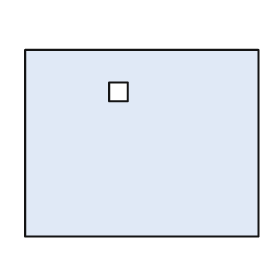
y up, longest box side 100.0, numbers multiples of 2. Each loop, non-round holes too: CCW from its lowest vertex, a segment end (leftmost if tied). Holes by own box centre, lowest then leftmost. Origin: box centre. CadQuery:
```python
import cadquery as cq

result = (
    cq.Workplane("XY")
    .moveTo(-50.0, -40.0)
    .lineTo(50.0, -40.0)
    .lineTo(50.0, 40.0)
    .lineTo(-50.0, 40.0)
    .close()
    .moveTo(-14.0, 18.0)
    .lineTo(-6.0, 18.0)
    .lineTo(-6.0, 26.0)
    .lineTo(-14.0, 26.0)
    .close()
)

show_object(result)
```